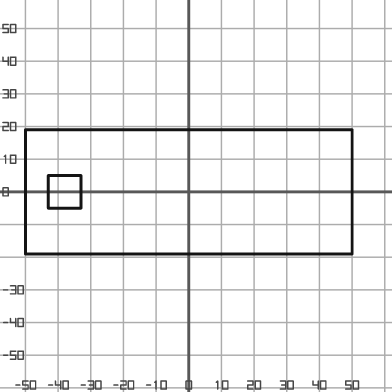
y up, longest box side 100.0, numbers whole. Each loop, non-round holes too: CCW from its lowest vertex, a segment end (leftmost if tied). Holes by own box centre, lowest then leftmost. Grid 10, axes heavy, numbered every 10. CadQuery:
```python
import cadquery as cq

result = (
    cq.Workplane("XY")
    .moveTo(-50.0, -19.0)
    .lineTo(50.0, -19.0)
    .lineTo(50.0, 19.0)
    .lineTo(-50.0, 19.0)
    .close()
    .moveTo(-43.0, -5.0)
    .lineTo(-33.0, -5.0)
    .lineTo(-33.0, 5.0)
    .lineTo(-43.0, 5.0)
    .close()
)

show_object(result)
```